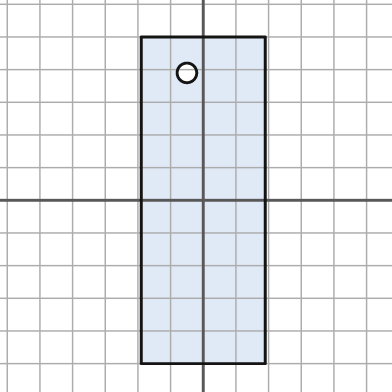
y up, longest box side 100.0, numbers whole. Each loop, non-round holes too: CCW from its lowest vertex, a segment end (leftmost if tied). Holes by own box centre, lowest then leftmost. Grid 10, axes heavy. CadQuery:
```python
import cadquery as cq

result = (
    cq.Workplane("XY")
    .moveTo(-19.0, -50.0)
    .lineTo(19.0, -50.0)
    .lineTo(19.0, 50.0)
    .lineTo(-19.0, 50.0)
    .close()
    .moveTo(-5.0, 39.0)
    .circle(3.0)
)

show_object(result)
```